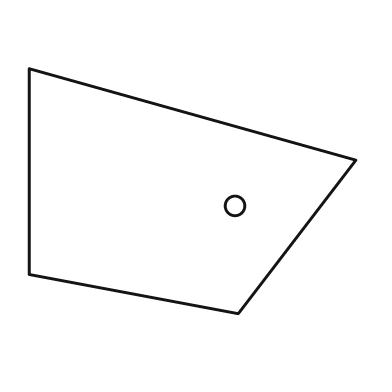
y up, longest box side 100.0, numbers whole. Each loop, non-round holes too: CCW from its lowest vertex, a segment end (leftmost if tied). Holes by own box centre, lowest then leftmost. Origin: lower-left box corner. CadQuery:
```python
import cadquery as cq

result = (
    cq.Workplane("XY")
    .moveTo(64.0, 0.0)
    .lineTo(100.0, 47.0)
    .lineTo(0.0, 75.0)
    .lineTo(0.0, 12.0)
    .close()
    .moveTo(63.0, 33.0)
    .circle(3.0)
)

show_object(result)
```